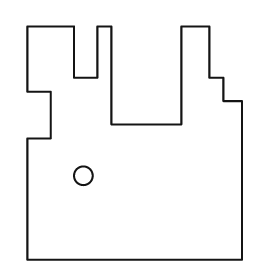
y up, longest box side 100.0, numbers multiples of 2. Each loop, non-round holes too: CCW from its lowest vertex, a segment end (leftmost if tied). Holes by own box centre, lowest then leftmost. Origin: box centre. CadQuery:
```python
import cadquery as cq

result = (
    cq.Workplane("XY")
    .moveTo(-46.0, -50.0)
    .lineTo(46.0, -50.0)
    .lineTo(46.0, 18.0)
    .lineTo(38.0, 18.0)
    .lineTo(38.0, 28.0)
    .lineTo(32.0, 28.0)
    .lineTo(32.0, 50.0)
    .lineTo(20.0, 50.0)
    .lineTo(20.0, 8.0)
    .lineTo(-10.0, 8.0)
    .lineTo(-10.0, 50.0)
    .lineTo(-16.0, 50.0)
    .lineTo(-16.0, 28.0)
    .lineTo(-26.0, 28.0)
    .lineTo(-26.0, 50.0)
    .lineTo(-46.0, 50.0)
    .lineTo(-46.0, 22.0)
    .lineTo(-36.0, 22.0)
    .lineTo(-36.0, 2.0)
    .lineTo(-46.0, 2.0)
    .close()
    .moveTo(-22.0, -14.0)
    .circle(4.0)
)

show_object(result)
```